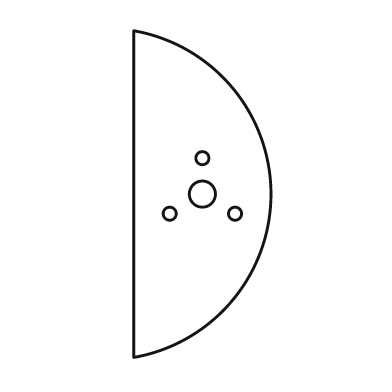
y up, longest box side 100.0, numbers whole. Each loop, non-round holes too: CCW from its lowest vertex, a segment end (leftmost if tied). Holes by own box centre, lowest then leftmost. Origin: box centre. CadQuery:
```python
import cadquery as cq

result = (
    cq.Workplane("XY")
    .moveTo(-21.0, -50.0)
    .threePointArc((21.0, 0.0), (-21.0, 50.0))
    .close()
    .moveTo(-10.0, -6.0)
    .circle(2.0)
    .moveTo(10.0, -6.0)
    .circle(2.0)
    .moveTo(0.0, 0.0)
    .circle(4.0)
    .moveTo(0.0, 11.0)
    .circle(2.0)
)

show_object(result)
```